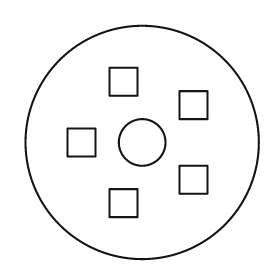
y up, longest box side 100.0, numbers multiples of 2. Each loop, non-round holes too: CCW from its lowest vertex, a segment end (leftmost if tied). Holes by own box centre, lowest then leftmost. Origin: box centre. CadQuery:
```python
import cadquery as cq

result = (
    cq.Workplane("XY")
    .moveTo(0.0, 0.0)
    .circle(50.0)
    .moveTo(-14.0, -32.0)
    .lineTo(-2.0, -32.0)
    .lineTo(-2.0, -20.0)
    .lineTo(-14.0, -20.0)
    .close()
    .moveTo(16.0, -22.0)
    .lineTo(28.0, -22.0)
    .lineTo(28.0, -10.0)
    .lineTo(16.0, -10.0)
    .close()
    .moveTo(-32.0, -6.0)
    .lineTo(-20.0, -6.0)
    .lineTo(-20.0, 6.0)
    .lineTo(-32.0, 6.0)
    .close()
    .moveTo(0.0, 0.0)
    .circle(10.0)
    .moveTo(16.0, 10.0)
    .lineTo(28.0, 10.0)
    .lineTo(28.0, 22.0)
    .lineTo(16.0, 22.0)
    .close()
    .moveTo(-14.0, 20.0)
    .lineTo(-2.0, 20.0)
    .lineTo(-2.0, 32.0)
    .lineTo(-14.0, 32.0)
    .close()
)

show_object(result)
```